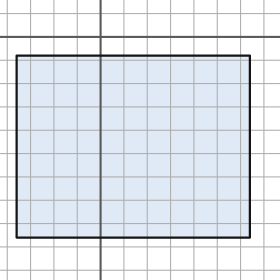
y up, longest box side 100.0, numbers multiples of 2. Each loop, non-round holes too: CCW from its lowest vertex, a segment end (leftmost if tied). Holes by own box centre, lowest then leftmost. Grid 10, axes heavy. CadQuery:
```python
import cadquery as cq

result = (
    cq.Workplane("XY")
    .moveTo(-36.0, -86.0)
    .lineTo(64.0, -86.0)
    .lineTo(64.0, -8.0)
    .lineTo(-36.0, -8.0)
    .close()
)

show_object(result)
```